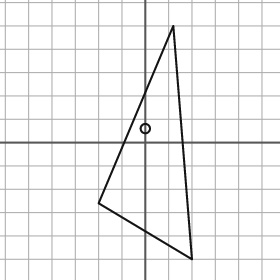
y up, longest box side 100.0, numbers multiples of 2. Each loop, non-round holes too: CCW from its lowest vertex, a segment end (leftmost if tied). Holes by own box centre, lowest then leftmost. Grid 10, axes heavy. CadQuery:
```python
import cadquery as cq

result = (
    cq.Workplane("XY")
    .moveTo(20.0, -50.0)
    .lineTo(12.0, 50.0)
    .lineTo(-20.0, -26.0)
    .close()
    .moveTo(0.0, 6.0)
    .circle(2.0)
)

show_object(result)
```